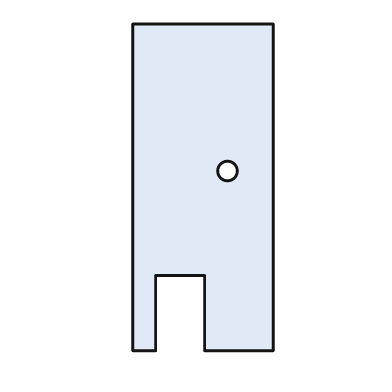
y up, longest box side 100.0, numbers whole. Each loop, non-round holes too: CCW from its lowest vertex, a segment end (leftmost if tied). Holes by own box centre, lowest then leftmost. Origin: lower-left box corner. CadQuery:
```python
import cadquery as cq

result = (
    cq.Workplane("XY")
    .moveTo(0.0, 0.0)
    .lineTo(7.0, 0.0)
    .lineTo(7.0, 23.0)
    .lineTo(22.0, 23.0)
    .lineTo(22.0, 0.0)
    .lineTo(43.0, 0.0)
    .lineTo(43.0, 100.0)
    .lineTo(0.0, 100.0)
    .close()
    .moveTo(29.0, 55.0)
    .circle(3.0)
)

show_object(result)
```